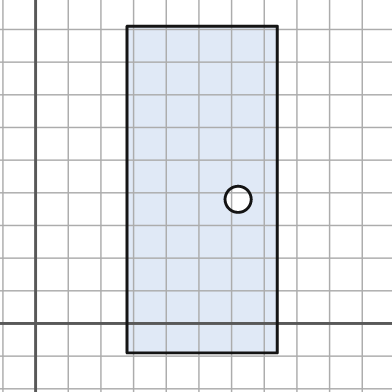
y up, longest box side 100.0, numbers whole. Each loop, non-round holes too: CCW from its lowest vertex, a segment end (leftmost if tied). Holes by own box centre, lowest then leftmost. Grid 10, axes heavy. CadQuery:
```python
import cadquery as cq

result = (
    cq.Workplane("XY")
    .moveTo(28.0, -9.0)
    .lineTo(74.0, -9.0)
    .lineTo(74.0, 91.0)
    .lineTo(28.0, 91.0)
    .close()
    .moveTo(62.0, 38.0)
    .circle(4.0)
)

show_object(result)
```